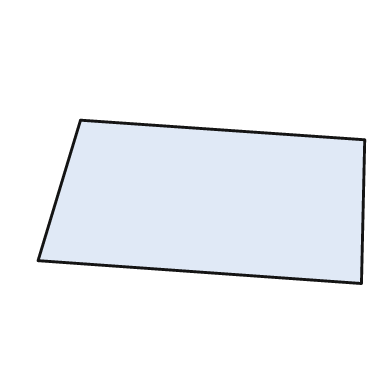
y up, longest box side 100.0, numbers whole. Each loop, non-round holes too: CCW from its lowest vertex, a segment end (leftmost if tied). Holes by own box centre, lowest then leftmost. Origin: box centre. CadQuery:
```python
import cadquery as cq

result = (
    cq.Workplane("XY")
    .moveTo(49.0, -25.0)
    .lineTo(50.0, 19.0)
    .lineTo(-37.0, 25.0)
    .lineTo(-50.0, -18.0)
    .close()
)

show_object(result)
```